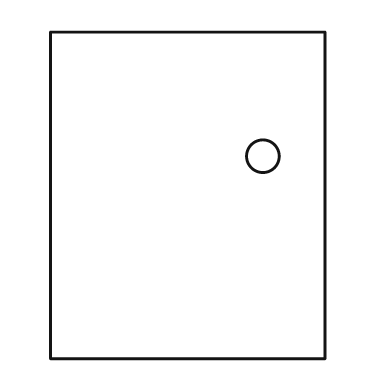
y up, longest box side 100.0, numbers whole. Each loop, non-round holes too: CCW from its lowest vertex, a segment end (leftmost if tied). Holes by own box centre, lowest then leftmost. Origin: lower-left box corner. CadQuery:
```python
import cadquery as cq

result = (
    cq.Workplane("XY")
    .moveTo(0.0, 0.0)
    .lineTo(84.0, 0.0)
    .lineTo(84.0, 100.0)
    .lineTo(0.0, 100.0)
    .close()
    .moveTo(65.0, 62.0)
    .circle(5.0)
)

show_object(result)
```